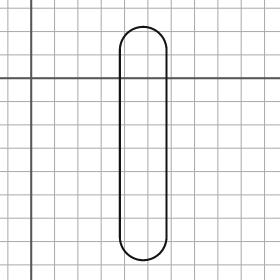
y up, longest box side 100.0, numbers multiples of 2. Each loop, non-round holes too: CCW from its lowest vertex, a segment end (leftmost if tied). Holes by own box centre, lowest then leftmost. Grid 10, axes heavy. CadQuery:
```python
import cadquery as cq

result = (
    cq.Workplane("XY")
    .moveTo(38.0, -68.0)
    .threePointArc((48.0, -78.0), (58.0, -68.0))
    .lineTo(58.0, 12.0)
    .threePointArc((48.0, 22.0), (38.0, 12.0))
    .close()
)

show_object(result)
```